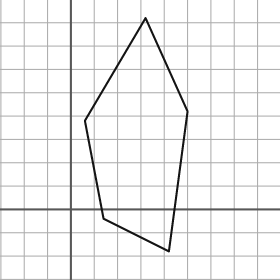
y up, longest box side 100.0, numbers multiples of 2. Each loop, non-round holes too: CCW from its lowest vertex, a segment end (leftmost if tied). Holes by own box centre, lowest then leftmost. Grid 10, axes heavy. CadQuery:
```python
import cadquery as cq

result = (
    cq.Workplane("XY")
    .moveTo(42.0, -18.0)
    .lineTo(50.0, 42.0)
    .lineTo(32.0, 82.0)
    .lineTo(6.0, 38.0)
    .lineTo(14.0, -4.0)
    .close()
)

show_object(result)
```